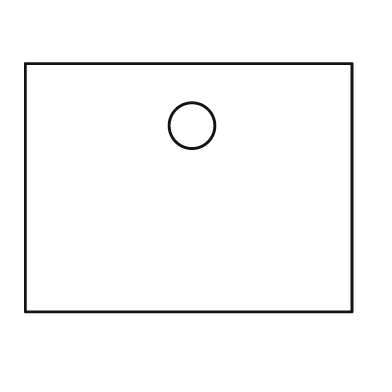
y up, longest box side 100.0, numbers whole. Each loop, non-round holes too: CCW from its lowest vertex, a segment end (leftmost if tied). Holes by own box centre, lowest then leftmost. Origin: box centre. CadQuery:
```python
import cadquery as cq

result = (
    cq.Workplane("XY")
    .moveTo(-50.0, -38.0)
    .lineTo(50.0, -38.0)
    .lineTo(50.0, 38.0)
    .lineTo(-50.0, 38.0)
    .close()
    .moveTo(1.0, 19.0)
    .circle(7.0)
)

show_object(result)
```